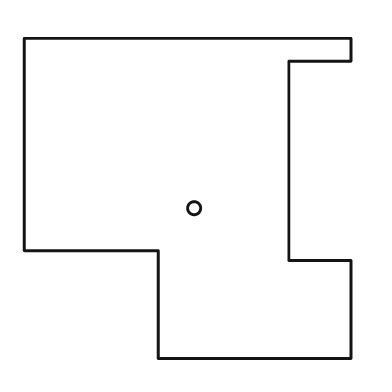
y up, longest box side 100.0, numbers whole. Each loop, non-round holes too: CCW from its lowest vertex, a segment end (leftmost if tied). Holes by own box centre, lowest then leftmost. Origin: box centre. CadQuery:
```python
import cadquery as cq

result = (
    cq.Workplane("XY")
    .moveTo(-9.0, -49.0)
    .lineTo(50.0, -49.0)
    .lineTo(50.0, -19.0)
    .lineTo(31.0, -19.0)
    .lineTo(31.0, 42.0)
    .lineTo(50.0, 42.0)
    .lineTo(50.0, 49.0)
    .lineTo(-50.0, 49.0)
    .lineTo(-50.0, -16.0)
    .lineTo(-9.0, -16.0)
    .close()
    .moveTo(2.0, -3.0)
    .circle(2.0)
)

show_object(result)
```